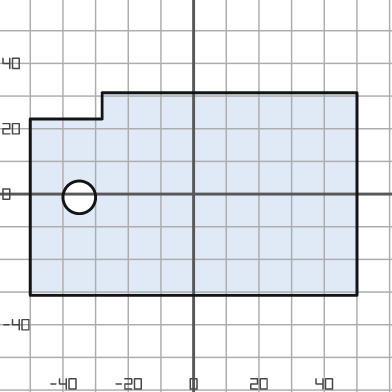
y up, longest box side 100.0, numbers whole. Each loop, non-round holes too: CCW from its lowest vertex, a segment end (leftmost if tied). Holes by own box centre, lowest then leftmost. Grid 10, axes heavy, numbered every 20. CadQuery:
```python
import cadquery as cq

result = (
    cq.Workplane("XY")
    .moveTo(-50.0, -31.0)
    .lineTo(50.0, -31.0)
    .lineTo(50.0, 31.0)
    .lineTo(-28.0, 31.0)
    .lineTo(-28.0, 23.0)
    .lineTo(-50.0, 23.0)
    .close()
    .moveTo(-35.0, -1.0)
    .circle(5.0)
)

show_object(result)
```